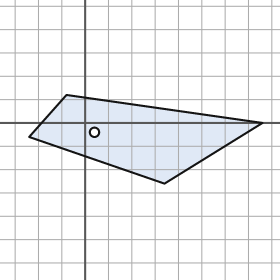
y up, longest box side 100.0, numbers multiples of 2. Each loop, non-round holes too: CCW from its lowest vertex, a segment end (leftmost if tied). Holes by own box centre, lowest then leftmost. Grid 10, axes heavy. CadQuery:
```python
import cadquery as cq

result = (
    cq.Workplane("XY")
    .moveTo(34.0, -26.0)
    .lineTo(76.0, 0.0)
    .lineTo(-8.0, 12.0)
    .lineTo(-24.0, -6.0)
    .close()
    .moveTo(4.0, -4.0)
    .circle(2.0)
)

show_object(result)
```